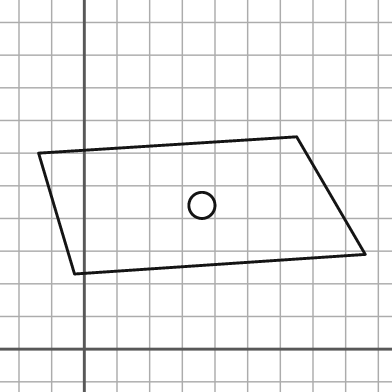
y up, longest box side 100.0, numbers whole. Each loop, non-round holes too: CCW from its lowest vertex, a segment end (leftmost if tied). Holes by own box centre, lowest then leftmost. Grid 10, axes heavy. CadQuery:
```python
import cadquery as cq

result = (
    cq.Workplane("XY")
    .moveTo(-3.0, 23.0)
    .lineTo(86.0, 29.0)
    .lineTo(65.0, 65.0)
    .lineTo(-14.0, 60.0)
    .close()
    .moveTo(36.0, 44.0)
    .circle(4.0)
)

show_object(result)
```